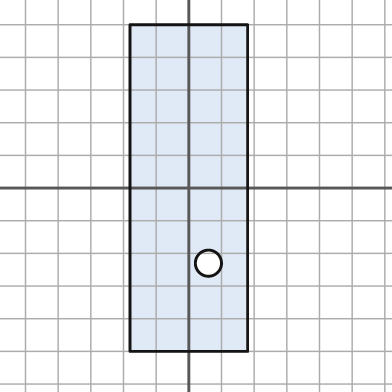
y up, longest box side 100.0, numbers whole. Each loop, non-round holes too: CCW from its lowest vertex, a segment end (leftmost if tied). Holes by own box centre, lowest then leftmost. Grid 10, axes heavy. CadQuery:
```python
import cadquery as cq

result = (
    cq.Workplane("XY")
    .moveTo(-18.0, -50.0)
    .lineTo(18.0, -50.0)
    .lineTo(18.0, 50.0)
    .lineTo(-18.0, 50.0)
    .close()
    .moveTo(6.0, -23.0)
    .circle(4.0)
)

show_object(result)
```